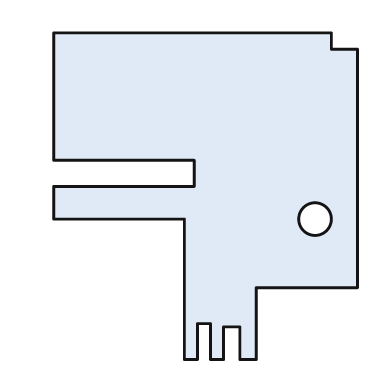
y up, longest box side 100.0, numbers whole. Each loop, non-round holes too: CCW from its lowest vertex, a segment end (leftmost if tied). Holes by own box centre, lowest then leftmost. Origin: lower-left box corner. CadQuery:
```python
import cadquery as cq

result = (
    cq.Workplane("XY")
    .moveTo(40.0, 0.0)
    .lineTo(44.0, 0.0)
    .lineTo(44.0, 11.0)
    .lineTo(48.0, 11.0)
    .lineTo(48.0, 0.0)
    .lineTo(52.0, 0.0)
    .lineTo(52.0, 10.0)
    .lineTo(57.0, 10.0)
    .lineTo(57.0, 0.0)
    .lineTo(62.0, 0.0)
    .lineTo(62.0, 22.0)
    .lineTo(93.0, 22.0)
    .lineTo(93.0, 95.0)
    .lineTo(85.0, 95.0)
    .lineTo(85.0, 100.0)
    .lineTo(0.0, 100.0)
    .lineTo(0.0, 61.0)
    .lineTo(43.0, 61.0)
    .lineTo(43.0, 53.0)
    .lineTo(0.0, 53.0)
    .lineTo(0.0, 43.0)
    .lineTo(40.0, 43.0)
    .close()
    .moveTo(80.0, 43.0)
    .circle(5.0)
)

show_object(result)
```